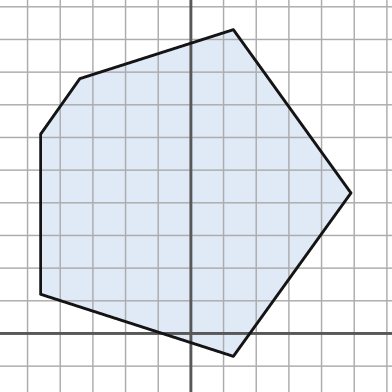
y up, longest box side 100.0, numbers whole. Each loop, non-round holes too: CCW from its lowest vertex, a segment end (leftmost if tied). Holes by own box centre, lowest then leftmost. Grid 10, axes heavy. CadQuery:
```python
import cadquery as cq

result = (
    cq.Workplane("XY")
    .moveTo(13.0, -7.0)
    .lineTo(49.0, 43.0)
    .lineTo(13.0, 93.0)
    .lineTo(-34.0, 78.0)
    .lineTo(-46.0, 61.0)
    .lineTo(-46.0, 12.0)
    .close()
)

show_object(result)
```